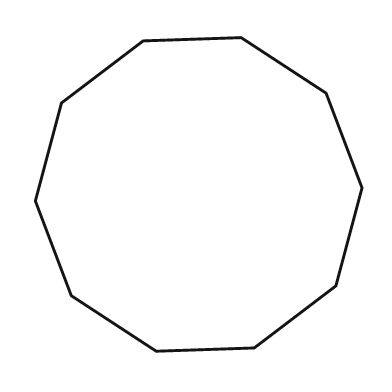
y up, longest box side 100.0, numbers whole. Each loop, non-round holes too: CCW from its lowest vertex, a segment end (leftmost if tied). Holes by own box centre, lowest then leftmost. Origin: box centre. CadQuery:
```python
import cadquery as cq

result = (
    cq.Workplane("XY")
    .moveTo(-13.0, -48.0)
    .lineTo(17.0, -47.0)
    .lineTo(42.0, -28.0)
    .lineTo(50.0, 2.0)
    .lineTo(39.0, 31.0)
    .lineTo(13.0, 48.0)
    .lineTo(-17.0, 47.0)
    .lineTo(-42.0, 28.0)
    .lineTo(-50.0, -2.0)
    .lineTo(-39.0, -31.0)
    .close()
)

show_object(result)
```